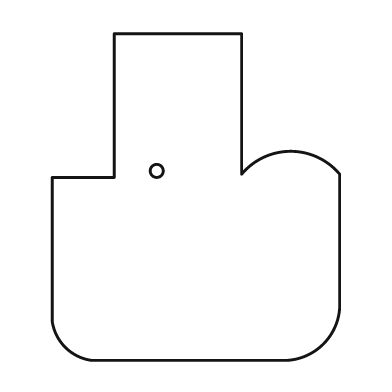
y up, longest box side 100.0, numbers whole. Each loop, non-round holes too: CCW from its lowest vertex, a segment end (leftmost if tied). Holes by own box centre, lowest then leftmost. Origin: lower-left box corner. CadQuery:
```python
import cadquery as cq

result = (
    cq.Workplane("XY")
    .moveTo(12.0, 0.0)
    .lineTo(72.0, 0.0)
    .threePointArc((83.0, 5.0), (88.0, 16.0))
    .lineTo(88.0, 57.0)
    .threePointArc((73.0, 64.0), (58.0, 57.0))
    .lineTo(58.0, 100.0)
    .lineTo(19.0, 100.0)
    .lineTo(19.0, 56.0)
    .lineTo(0.0, 56.0)
    .lineTo(0.0, 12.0)
    .threePointArc((4.0, 4.0), (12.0, 0.0))
    .close()
    .moveTo(32.0, 58.0)
    .circle(2.0)
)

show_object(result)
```